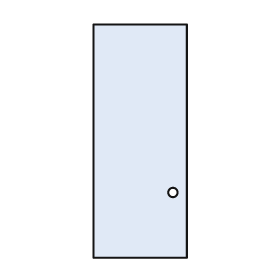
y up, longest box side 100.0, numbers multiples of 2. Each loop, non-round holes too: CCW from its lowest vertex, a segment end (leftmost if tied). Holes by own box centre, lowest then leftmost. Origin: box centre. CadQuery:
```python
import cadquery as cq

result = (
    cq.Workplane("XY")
    .moveTo(-20.0, -50.0)
    .lineTo(20.0, -50.0)
    .lineTo(20.0, 50.0)
    .lineTo(-20.0, 50.0)
    .close()
    .moveTo(14.0, -22.0)
    .circle(2.0)
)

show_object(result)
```